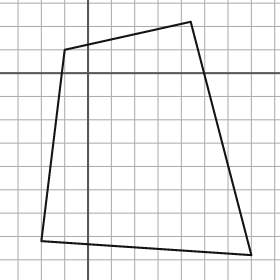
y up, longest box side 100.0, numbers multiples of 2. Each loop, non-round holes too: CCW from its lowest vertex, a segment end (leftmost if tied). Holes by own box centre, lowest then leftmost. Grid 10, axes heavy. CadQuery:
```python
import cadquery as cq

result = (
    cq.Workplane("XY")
    .moveTo(70.0, -78.0)
    .lineTo(44.0, 22.0)
    .lineTo(-10.0, 10.0)
    .lineTo(-20.0, -72.0)
    .close()
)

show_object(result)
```